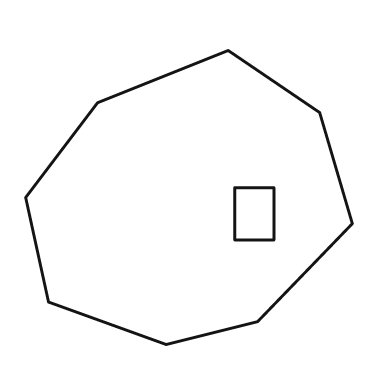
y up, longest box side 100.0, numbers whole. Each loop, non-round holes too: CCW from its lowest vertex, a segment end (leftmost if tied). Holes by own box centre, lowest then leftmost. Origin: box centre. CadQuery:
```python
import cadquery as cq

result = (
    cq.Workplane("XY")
    .moveTo(-7.0, -45.0)
    .lineTo(21.0, -38.0)
    .lineTo(50.0, -8.0)
    .lineTo(40.0, 26.0)
    .lineTo(12.0, 45.0)
    .lineTo(-28.0, 29.0)
    .lineTo(-50.0, 0.0)
    .lineTo(-43.0, -32.0)
    .close()
    .moveTo(14.0, -13.0)
    .lineTo(26.0, -13.0)
    .lineTo(26.0, 3.0)
    .lineTo(14.0, 3.0)
    .close()
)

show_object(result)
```